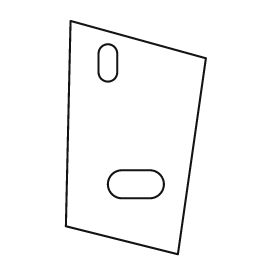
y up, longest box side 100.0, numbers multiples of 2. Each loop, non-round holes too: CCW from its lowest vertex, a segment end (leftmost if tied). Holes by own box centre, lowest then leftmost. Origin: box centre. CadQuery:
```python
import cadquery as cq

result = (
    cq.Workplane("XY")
    .moveTo(18.0, -50.0)
    .lineTo(30.0, 34.0)
    .lineTo(-28.0, 50.0)
    .lineTo(-30.0, -38.0)
    .close()
    .moveTo(-6.0, -26.0)
    .lineTo(6.0, -26.0)
    .threePointArc((12.0, -20.0), (6.0, -14.0))
    .lineTo(-6.0, -14.0)
    .threePointArc((-12.0, -20.0), (-6.0, -26.0))
    .close()
    .moveTo(-16.0, 28.0)
    .threePointArc((-12.0, 24.0), (-8.0, 28.0))
    .lineTo(-8.0, 36.0)
    .threePointArc((-12.0, 40.0), (-16.0, 36.0))
    .close()
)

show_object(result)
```